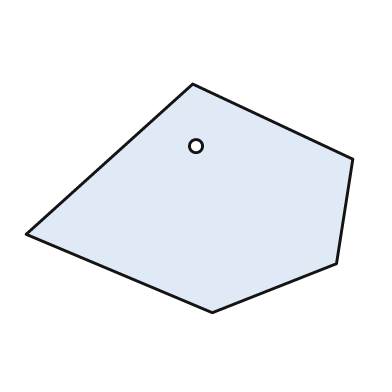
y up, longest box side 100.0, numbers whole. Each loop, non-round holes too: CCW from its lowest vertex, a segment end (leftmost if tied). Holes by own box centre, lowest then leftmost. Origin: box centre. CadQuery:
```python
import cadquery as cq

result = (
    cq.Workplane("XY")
    .moveTo(7.0, -35.0)
    .lineTo(45.0, -20.0)
    .lineTo(50.0, 12.0)
    .lineTo(1.0, 35.0)
    .lineTo(-50.0, -11.0)
    .close()
    .moveTo(2.0, 16.0)
    .circle(2.0)
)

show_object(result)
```